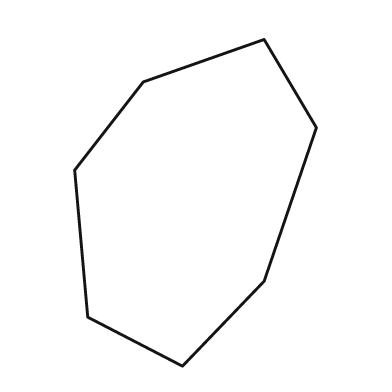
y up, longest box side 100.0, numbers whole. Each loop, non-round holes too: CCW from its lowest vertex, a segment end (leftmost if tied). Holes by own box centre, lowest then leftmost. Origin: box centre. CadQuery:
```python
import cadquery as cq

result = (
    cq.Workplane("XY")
    .moveTo(-4.0, -50.0)
    .lineTo(21.0, -24.0)
    .lineTo(37.0, 23.0)
    .lineTo(21.0, 50.0)
    .lineTo(-16.0, 37.0)
    .lineTo(-37.0, 10.0)
    .lineTo(-33.0, -35.0)
    .close()
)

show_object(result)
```